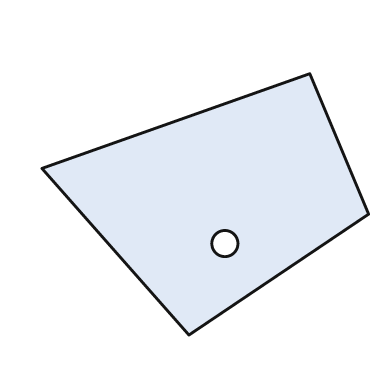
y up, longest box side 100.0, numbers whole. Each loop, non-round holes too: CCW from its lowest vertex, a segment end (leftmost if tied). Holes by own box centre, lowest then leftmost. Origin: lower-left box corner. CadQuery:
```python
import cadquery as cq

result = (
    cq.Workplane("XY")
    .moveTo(45.0, 0.0)
    .lineTo(100.0, 37.0)
    .lineTo(82.0, 80.0)
    .lineTo(0.0, 51.0)
    .close()
    .moveTo(56.0, 28.0)
    .circle(4.0)
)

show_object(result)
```